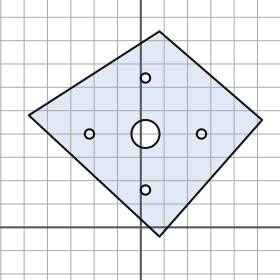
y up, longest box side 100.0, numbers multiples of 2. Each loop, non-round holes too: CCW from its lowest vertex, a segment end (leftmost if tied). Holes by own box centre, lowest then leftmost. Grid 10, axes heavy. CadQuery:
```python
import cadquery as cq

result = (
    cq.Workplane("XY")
    .moveTo(8.0, -4.0)
    .lineTo(52.0, 46.0)
    .lineTo(8.0, 84.0)
    .lineTo(-48.0, 48.0)
    .close()
    .moveTo(2.0, 16.0)
    .circle(2.0)
    .moveTo(-22.0, 40.0)
    .circle(2.0)
    .moveTo(2.0, 40.0)
    .circle(6.0)
    .moveTo(26.0, 40.0)
    .circle(2.0)
    .moveTo(2.0, 64.0)
    .circle(2.0)
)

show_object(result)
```